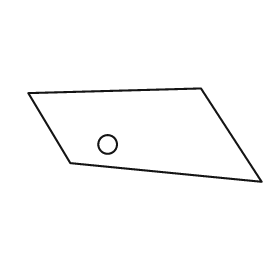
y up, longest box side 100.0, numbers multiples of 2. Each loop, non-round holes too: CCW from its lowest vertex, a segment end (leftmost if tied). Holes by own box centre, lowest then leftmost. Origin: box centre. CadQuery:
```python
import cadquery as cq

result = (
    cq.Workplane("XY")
    .moveTo(50.0, -20.0)
    .lineTo(24.0, 20.0)
    .lineTo(-50.0, 18.0)
    .lineTo(-32.0, -12.0)
    .close()
    .moveTo(-16.0, -4.0)
    .circle(4.0)
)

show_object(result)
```